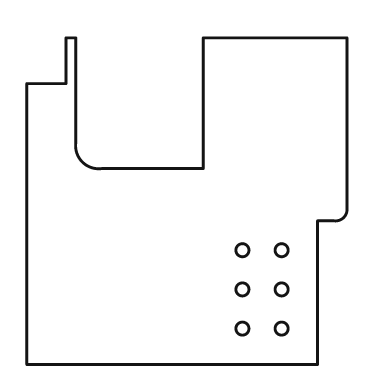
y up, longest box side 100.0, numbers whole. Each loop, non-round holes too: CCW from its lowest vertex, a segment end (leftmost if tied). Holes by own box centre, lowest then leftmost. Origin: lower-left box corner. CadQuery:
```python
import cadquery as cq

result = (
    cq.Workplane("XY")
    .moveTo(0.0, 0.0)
    .lineTo(89.0, 0.0)
    .lineTo(89.0, 44.0)
    .lineTo(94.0, 44.0)
    .threePointArc((97.0, 45.0), (98.0, 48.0))
    .lineTo(98.0, 100.0)
    .lineTo(54.0, 100.0)
    .lineTo(54.0, 60.0)
    .lineTo(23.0, 60.0)
    .threePointArc((17.0, 62.0), (15.0, 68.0))
    .lineTo(15.0, 100.0)
    .lineTo(12.0, 100.0)
    .lineTo(12.0, 86.0)
    .lineTo(0.0, 86.0)
    .close()
    .moveTo(66.0, 11.0)
    .circle(2.0)
    .moveTo(78.0, 11.0)
    .circle(2.0)
    .moveTo(66.0, 23.0)
    .circle(2.0)
    .moveTo(78.0, 23.0)
    .circle(2.0)
    .moveTo(66.0, 35.0)
    .circle(2.0)
    .moveTo(78.0, 35.0)
    .circle(2.0)
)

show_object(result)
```